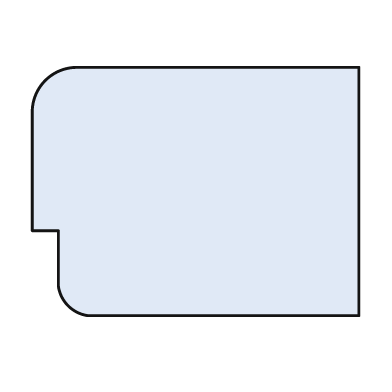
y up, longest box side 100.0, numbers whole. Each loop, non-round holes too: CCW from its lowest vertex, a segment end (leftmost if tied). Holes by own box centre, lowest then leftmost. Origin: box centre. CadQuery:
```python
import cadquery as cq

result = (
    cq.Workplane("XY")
    .moveTo(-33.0, -38.0)
    .lineTo(50.0, -38.0)
    .lineTo(50.0, 38.0)
    .lineTo(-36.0, 38.0)
    .threePointArc((-46.0, 34.0), (-50.0, 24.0))
    .lineTo(-50.0, -12.0)
    .lineTo(-42.0, -12.0)
    .lineTo(-42.0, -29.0)
    .threePointArc((-39.0, -35.0), (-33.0, -38.0))
    .close()
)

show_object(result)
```